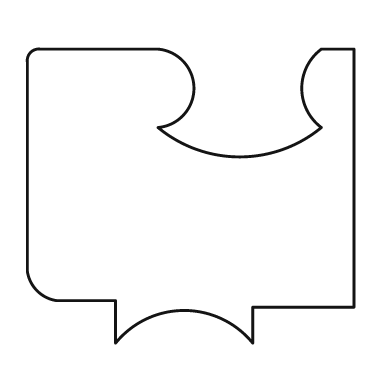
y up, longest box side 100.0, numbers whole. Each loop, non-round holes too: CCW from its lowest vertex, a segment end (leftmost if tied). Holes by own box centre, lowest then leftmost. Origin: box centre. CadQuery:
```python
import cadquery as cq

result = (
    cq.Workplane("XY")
    .moveTo(-23.0, -45.0)
    .threePointArc((-2.0, -35.0), (19.0, -45.0))
    .lineTo(19.0, -34.0)
    .lineTo(50.0, -34.0)
    .lineTo(50.0, 45.0)
    .lineTo(40.0, 45.0)
    .threePointArc((34.0, 33.0), (40.0, 21.0))
    .threePointArc((15.0, 12.0), (-10.0, 21.0))
    .threePointArc((1.0, 33.0), (-10.0, 45.0))
    .lineTo(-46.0, 45.0)
    .threePointArc((-49.0, 44.0), (-50.0, 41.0))
    .lineTo(-50.0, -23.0)
    .threePointArc((-47.0, -29.0), (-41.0, -32.0))
    .lineTo(-23.0, -32.0)
    .close()
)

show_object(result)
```